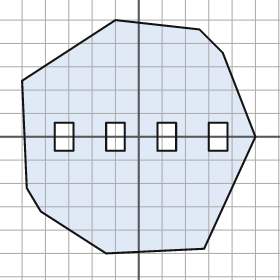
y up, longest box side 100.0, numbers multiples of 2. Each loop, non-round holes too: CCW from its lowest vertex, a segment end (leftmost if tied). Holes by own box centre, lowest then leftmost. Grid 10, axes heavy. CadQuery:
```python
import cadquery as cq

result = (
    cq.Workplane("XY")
    .moveTo(-14.0, -50.0)
    .lineTo(28.0, -48.0)
    .lineTo(50.0, 0.0)
    .lineTo(36.0, 36.0)
    .lineTo(26.0, 46.0)
    .lineTo(-10.0, 50.0)
    .lineTo(-50.0, 24.0)
    .lineTo(-48.0, -22.0)
    .lineTo(-42.0, -32.0)
    .close()
    .moveTo(-36.0, -6.0)
    .lineTo(-28.0, -6.0)
    .lineTo(-28.0, 6.0)
    .lineTo(-36.0, 6.0)
    .close()
    .moveTo(-14.0, -6.0)
    .lineTo(-6.0, -6.0)
    .lineTo(-6.0, 6.0)
    .lineTo(-14.0, 6.0)
    .close()
    .moveTo(8.0, -6.0)
    .lineTo(16.0, -6.0)
    .lineTo(16.0, 6.0)
    .lineTo(8.0, 6.0)
    .close()
    .moveTo(30.0, -6.0)
    .lineTo(38.0, -6.0)
    .lineTo(38.0, 6.0)
    .lineTo(30.0, 6.0)
    .close()
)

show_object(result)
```